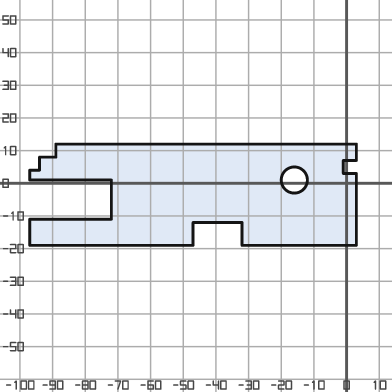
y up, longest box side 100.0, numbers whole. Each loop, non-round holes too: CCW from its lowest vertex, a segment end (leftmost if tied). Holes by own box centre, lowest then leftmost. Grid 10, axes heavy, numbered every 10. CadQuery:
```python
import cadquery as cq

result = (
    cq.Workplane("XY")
    .moveTo(-97.0, -19.0)
    .lineTo(-47.0, -19.0)
    .lineTo(-47.0, -12.0)
    .lineTo(-32.0, -12.0)
    .lineTo(-32.0, -19.0)
    .lineTo(3.0, -19.0)
    .lineTo(3.0, 3.0)
    .lineTo(-1.0, 3.0)
    .lineTo(-1.0, 7.0)
    .lineTo(3.0, 7.0)
    .lineTo(3.0, 12.0)
    .lineTo(-89.0, 12.0)
    .lineTo(-89.0, 8.0)
    .lineTo(-94.0, 8.0)
    .lineTo(-94.0, 4.0)
    .lineTo(-97.0, 4.0)
    .lineTo(-97.0, 1.0)
    .lineTo(-72.0, 1.0)
    .lineTo(-72.0, -11.0)
    .lineTo(-97.0, -11.0)
    .close()
    .moveTo(-16.0, 1.0)
    .circle(4.0)
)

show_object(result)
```